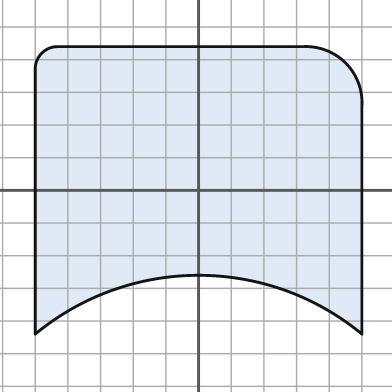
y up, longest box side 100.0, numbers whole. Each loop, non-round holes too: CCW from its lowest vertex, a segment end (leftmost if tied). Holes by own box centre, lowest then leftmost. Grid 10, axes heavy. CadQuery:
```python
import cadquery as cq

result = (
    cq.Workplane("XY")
    .moveTo(-50.0, -44.0)
    .threePointArc((0.0, -26.0), (50.0, -44.0))
    .lineTo(50.0, 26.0)
    .threePointArc((45.0, 39.0), (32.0, 44.0))
    .lineTo(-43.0, 44.0)
    .threePointArc((-48.0, 42.0), (-50.0, 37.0))
    .close()
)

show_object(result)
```